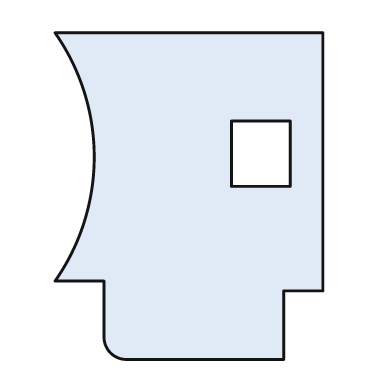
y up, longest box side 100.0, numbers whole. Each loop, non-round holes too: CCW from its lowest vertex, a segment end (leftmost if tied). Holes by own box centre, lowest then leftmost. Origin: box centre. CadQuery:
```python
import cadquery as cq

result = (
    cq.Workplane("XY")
    .moveTo(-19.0, -50.0)
    .lineTo(29.0, -50.0)
    .lineTo(29.0, -29.0)
    .lineTo(41.0, -29.0)
    .lineTo(41.0, 50.0)
    .lineTo(-41.0, 50.0)
    .threePointArc((-29.0, 12.0), (-41.0, -26.0))
    .lineTo(-26.0, -26.0)
    .lineTo(-26.0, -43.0)
    .threePointArc((-24.0, -48.0), (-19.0, -50.0))
    .close()
    .moveTo(13.0, 3.0)
    .lineTo(31.0, 3.0)
    .lineTo(31.0, 23.0)
    .lineTo(13.0, 23.0)
    .close()
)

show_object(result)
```